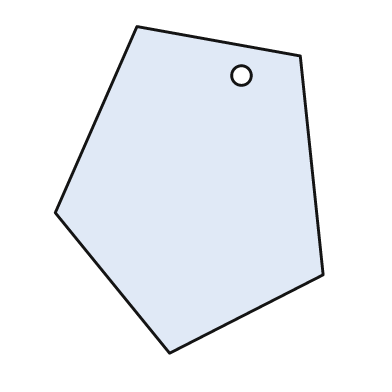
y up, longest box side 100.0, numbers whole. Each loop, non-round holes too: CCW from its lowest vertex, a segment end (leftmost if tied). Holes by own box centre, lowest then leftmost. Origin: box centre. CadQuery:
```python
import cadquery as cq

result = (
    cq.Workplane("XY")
    .moveTo(-6.0, -50.0)
    .lineTo(41.0, -26.0)
    .lineTo(34.0, 41.0)
    .lineTo(-16.0, 50.0)
    .lineTo(-41.0, -7.0)
    .close()
    .moveTo(16.0, 35.0)
    .circle(3.0)
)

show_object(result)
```